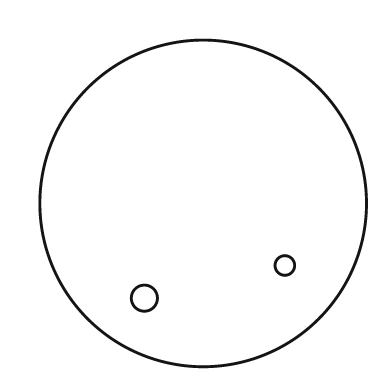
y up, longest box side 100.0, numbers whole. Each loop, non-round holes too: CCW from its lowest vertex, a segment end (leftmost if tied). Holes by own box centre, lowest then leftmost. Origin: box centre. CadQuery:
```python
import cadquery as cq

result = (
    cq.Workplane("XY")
    .moveTo(0.0, 0.0)
    .circle(50.0)
    .moveTo(-18.0, -29.0)
    .circle(4.0)
    .moveTo(25.0, -19.0)
    .circle(3.0)
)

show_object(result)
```